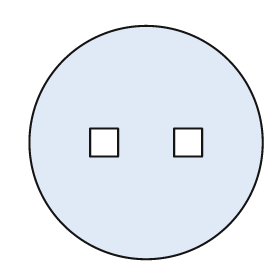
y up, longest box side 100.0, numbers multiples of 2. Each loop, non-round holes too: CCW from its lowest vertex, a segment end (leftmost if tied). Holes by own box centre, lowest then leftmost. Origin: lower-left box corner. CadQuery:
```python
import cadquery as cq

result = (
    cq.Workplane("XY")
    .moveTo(50.0, 50.0)
    .circle(50.0)
    .moveTo(26.0, 44.0)
    .lineTo(38.0, 44.0)
    .lineTo(38.0, 56.0)
    .lineTo(26.0, 56.0)
    .close()
    .moveTo(62.0, 44.0)
    .lineTo(74.0, 44.0)
    .lineTo(74.0, 56.0)
    .lineTo(62.0, 56.0)
    .close()
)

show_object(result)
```